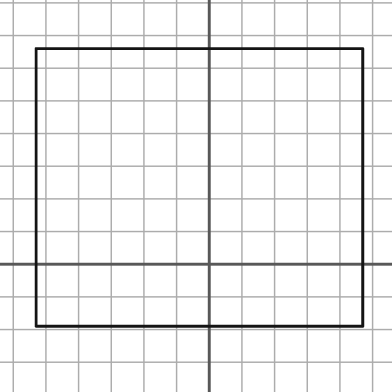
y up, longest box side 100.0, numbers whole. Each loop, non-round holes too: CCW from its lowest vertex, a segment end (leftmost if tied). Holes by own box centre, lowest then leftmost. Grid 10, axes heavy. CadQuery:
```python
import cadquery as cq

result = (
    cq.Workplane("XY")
    .moveTo(-53.0, -19.0)
    .lineTo(47.0, -19.0)
    .lineTo(47.0, 66.0)
    .lineTo(-53.0, 66.0)
    .close()
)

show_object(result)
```